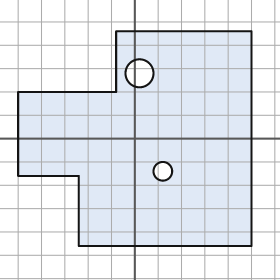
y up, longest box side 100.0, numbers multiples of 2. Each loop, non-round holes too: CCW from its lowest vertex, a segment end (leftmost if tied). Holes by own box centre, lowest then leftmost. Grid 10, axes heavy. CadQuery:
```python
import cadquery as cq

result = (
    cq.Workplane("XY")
    .moveTo(-24.0, -46.0)
    .lineTo(50.0, -46.0)
    .lineTo(50.0, 46.0)
    .lineTo(-8.0, 46.0)
    .lineTo(-8.0, 20.0)
    .lineTo(-50.0, 20.0)
    .lineTo(-50.0, -16.0)
    .lineTo(-24.0, -16.0)
    .close()
    .moveTo(12.0, -14.0)
    .circle(4.0)
    .moveTo(2.0, 28.0)
    .circle(6.0)
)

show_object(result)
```